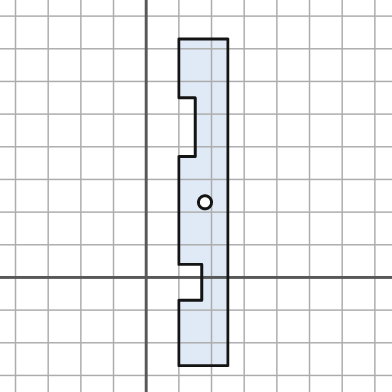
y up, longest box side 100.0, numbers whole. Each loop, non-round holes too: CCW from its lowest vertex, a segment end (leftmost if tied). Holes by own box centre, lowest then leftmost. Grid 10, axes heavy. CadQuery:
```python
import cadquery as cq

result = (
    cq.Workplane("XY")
    .moveTo(10.0, -27.0)
    .lineTo(25.0, -27.0)
    .lineTo(25.0, 73.0)
    .lineTo(10.0, 73.0)
    .lineTo(10.0, 55.0)
    .lineTo(15.0, 55.0)
    .lineTo(15.0, 37.0)
    .lineTo(10.0, 37.0)
    .lineTo(10.0, 4.0)
    .lineTo(17.0, 4.0)
    .lineTo(17.0, -7.0)
    .lineTo(10.0, -7.0)
    .close()
    .moveTo(18.0, 23.0)
    .circle(2.0)
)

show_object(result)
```